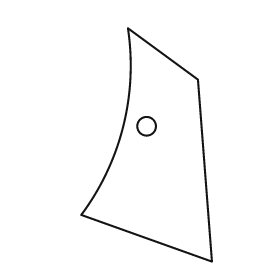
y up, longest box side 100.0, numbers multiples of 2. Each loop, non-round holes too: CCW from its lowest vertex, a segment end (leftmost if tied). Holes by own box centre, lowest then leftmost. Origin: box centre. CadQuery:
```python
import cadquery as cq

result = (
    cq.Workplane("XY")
    .moveTo(28.0, -50.0)
    .lineTo(22.0, 28.0)
    .lineTo(-8.0, 50.0)
    .threePointArc((-10.0, 8.0), (-28.0, -30.0))
    .close()
    .moveTo(0.0, 8.0)
    .circle(4.0)
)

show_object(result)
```